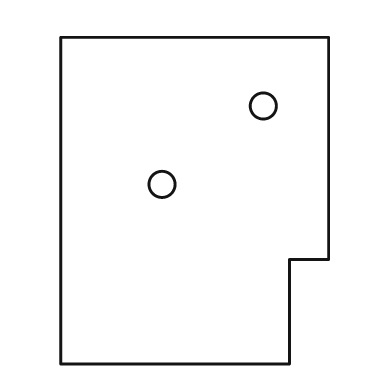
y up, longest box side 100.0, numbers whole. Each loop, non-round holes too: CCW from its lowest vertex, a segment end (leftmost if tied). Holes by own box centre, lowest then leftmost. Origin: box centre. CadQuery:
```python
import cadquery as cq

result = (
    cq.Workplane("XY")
    .moveTo(-41.0, -50.0)
    .lineTo(29.0, -50.0)
    .lineTo(29.0, -18.0)
    .lineTo(41.0, -18.0)
    .lineTo(41.0, 50.0)
    .lineTo(-41.0, 50.0)
    .close()
    .moveTo(-10.0, 5.0)
    .circle(4.0)
    .moveTo(21.0, 29.0)
    .circle(4.0)
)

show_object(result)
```